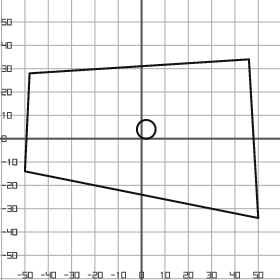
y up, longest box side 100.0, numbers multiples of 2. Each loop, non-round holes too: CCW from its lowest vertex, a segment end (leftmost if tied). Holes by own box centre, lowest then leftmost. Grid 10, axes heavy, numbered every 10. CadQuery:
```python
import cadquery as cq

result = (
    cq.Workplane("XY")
    .moveTo(50.0, -34.0)
    .lineTo(46.0, 34.0)
    .lineTo(-48.0, 28.0)
    .lineTo(-50.0, -14.0)
    .close()
    .moveTo(2.0, 4.0)
    .circle(4.0)
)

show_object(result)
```